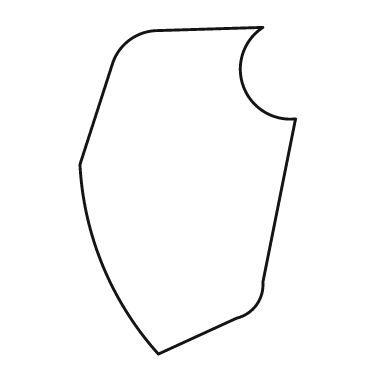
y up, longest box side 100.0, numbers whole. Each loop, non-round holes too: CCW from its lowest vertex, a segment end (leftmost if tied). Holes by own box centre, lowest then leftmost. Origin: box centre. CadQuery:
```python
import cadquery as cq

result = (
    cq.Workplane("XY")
    .moveTo(-9.0, -50.0)
    .lineTo(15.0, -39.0)
    .threePointArc((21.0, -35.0), (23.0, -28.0))
    .lineTo(33.0, 22.0)
    .threePointArc((17.0, 32.0), (23.0, 50.0))
    .lineTo(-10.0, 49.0)
    .threePointArc((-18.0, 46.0), (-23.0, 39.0))
    .lineTo(-33.0, 8.0)
    .threePointArc((-26.0, -23.0), (-9.0, -50.0))
    .close()
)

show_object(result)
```